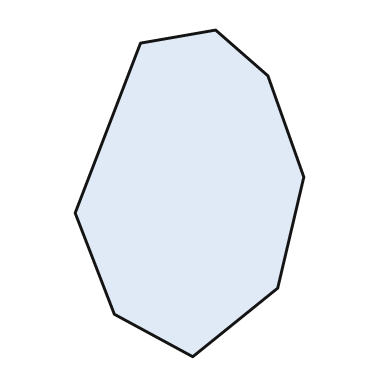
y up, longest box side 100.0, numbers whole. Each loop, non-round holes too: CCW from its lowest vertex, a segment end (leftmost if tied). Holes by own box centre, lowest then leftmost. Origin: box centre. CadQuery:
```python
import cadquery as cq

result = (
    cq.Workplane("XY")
    .moveTo(1.0, -50.0)
    .lineTo(27.0, -29.0)
    .lineTo(35.0, 5.0)
    .lineTo(24.0, 36.0)
    .lineTo(8.0, 50.0)
    .lineTo(-15.0, 46.0)
    .lineTo(-35.0, -6.0)
    .lineTo(-23.0, -37.0)
    .close()
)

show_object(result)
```